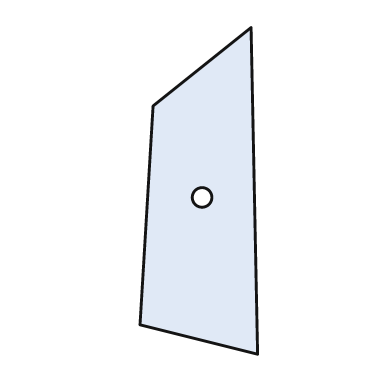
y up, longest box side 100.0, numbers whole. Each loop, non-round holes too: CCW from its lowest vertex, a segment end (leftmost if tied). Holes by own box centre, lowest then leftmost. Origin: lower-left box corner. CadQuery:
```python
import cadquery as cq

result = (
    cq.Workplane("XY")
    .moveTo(36.0, 0.0)
    .lineTo(34.0, 100.0)
    .lineTo(4.0, 76.0)
    .lineTo(0.0, 9.0)
    .close()
    .moveTo(19.0, 48.0)
    .circle(3.0)
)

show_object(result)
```